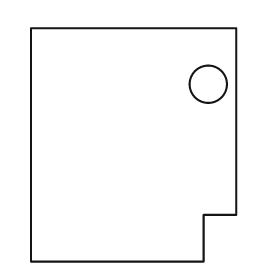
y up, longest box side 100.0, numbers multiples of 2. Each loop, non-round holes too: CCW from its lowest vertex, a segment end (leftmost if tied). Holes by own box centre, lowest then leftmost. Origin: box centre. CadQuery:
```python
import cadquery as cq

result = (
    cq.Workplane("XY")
    .moveTo(-44.0, -50.0)
    .lineTo(30.0, -50.0)
    .lineTo(30.0, -30.0)
    .lineTo(44.0, -30.0)
    .lineTo(44.0, 50.0)
    .lineTo(-44.0, 50.0)
    .close()
    .moveTo(32.0, 26.0)
    .circle(8.0)
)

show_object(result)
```